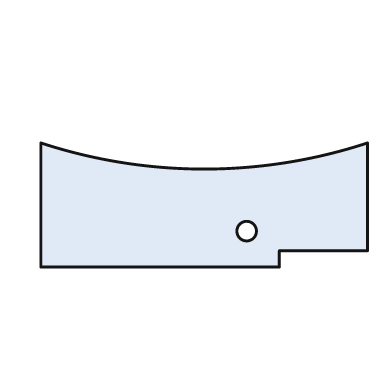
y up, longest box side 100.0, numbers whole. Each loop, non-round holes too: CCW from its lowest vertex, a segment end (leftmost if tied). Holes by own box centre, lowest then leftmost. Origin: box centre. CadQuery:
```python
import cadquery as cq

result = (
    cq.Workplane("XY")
    .moveTo(-50.0, -19.0)
    .lineTo(23.0, -19.0)
    .lineTo(23.0, -14.0)
    .lineTo(50.0, -14.0)
    .lineTo(50.0, 19.0)
    .threePointArc((0.0, 11.0), (-50.0, 19.0))
    .close()
    .moveTo(13.0, -8.0)
    .circle(3.0)
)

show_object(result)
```